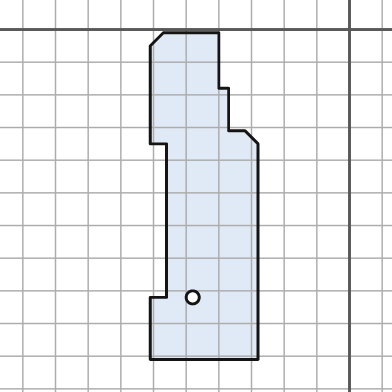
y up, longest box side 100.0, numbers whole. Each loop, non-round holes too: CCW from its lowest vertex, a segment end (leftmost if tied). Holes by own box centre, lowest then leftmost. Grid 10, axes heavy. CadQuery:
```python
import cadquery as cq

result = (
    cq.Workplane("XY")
    .moveTo(-61.0, -101.0)
    .lineTo(-28.0, -101.0)
    .lineTo(-28.0, -35.0)
    .lineTo(-32.0, -31.0)
    .lineTo(-37.0, -31.0)
    .lineTo(-37.0, -18.0)
    .lineTo(-40.0, -18.0)
    .lineTo(-40.0, -1.0)
    .lineTo(-57.0, -1.0)
    .lineTo(-61.0, -5.0)
    .lineTo(-61.0, -35.0)
    .lineTo(-56.0, -35.0)
    .lineTo(-56.0, -82.0)
    .lineTo(-61.0, -82.0)
    .close()
    .moveTo(-48.0, -82.0)
    .circle(2.0)
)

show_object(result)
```